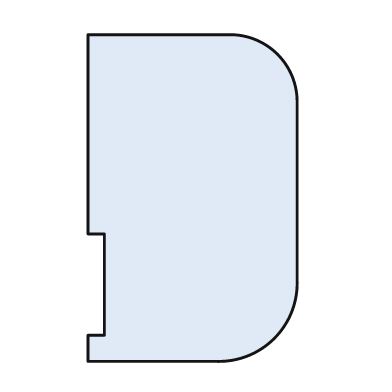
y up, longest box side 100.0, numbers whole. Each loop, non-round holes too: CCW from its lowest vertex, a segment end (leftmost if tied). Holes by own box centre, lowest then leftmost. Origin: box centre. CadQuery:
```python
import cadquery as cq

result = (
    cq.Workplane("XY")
    .moveTo(-32.0, -50.0)
    .lineTo(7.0, -50.0)
    .threePointArc((25.0, -43.0), (32.0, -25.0))
    .lineTo(32.0, 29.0)
    .threePointArc((26.0, 44.0), (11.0, 50.0))
    .lineTo(-32.0, 50.0)
    .lineTo(-32.0, -11.0)
    .lineTo(-27.0, -11.0)
    .lineTo(-27.0, -42.0)
    .lineTo(-32.0, -42.0)
    .close()
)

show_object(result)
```